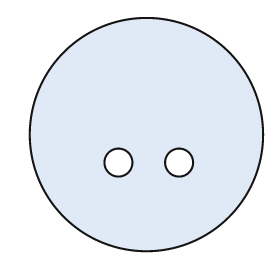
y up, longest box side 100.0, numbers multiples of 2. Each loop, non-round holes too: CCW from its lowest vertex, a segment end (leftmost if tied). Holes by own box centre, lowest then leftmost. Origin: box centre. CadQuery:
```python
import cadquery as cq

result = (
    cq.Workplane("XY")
    .moveTo(0.0, 0.0)
    .circle(50.0)
    .moveTo(-12.0, -12.0)
    .circle(6.0)
    .moveTo(14.0, -12.0)
    .circle(6.0)
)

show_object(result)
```